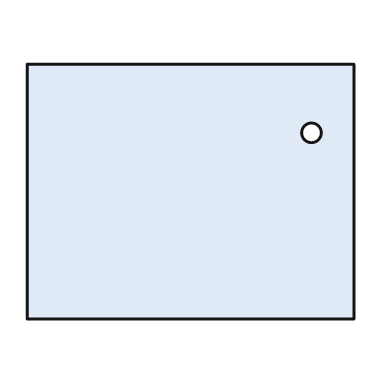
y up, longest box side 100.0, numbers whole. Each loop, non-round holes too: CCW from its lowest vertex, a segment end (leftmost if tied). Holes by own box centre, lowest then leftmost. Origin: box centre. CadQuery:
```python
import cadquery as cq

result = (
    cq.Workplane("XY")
    .moveTo(-50.0, -39.0)
    .lineTo(50.0, -39.0)
    .lineTo(50.0, 39.0)
    .lineTo(-50.0, 39.0)
    .close()
    .moveTo(37.0, 18.0)
    .circle(3.0)
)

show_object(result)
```